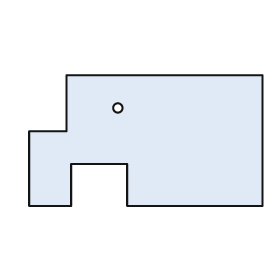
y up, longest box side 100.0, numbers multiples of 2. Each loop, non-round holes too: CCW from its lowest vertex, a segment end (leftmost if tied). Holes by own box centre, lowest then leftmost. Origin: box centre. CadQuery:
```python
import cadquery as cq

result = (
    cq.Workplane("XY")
    .moveTo(-50.0, -28.0)
    .lineTo(-32.0, -28.0)
    .lineTo(-32.0, -10.0)
    .lineTo(-8.0, -10.0)
    .lineTo(-8.0, -28.0)
    .lineTo(50.0, -28.0)
    .lineTo(50.0, 28.0)
    .lineTo(-34.0, 28.0)
    .lineTo(-34.0, 4.0)
    .lineTo(-50.0, 4.0)
    .close()
    .moveTo(-12.0, 14.0)
    .circle(2.0)
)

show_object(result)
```